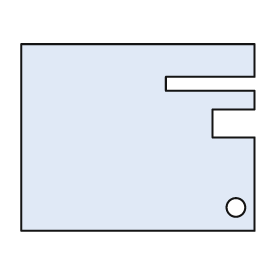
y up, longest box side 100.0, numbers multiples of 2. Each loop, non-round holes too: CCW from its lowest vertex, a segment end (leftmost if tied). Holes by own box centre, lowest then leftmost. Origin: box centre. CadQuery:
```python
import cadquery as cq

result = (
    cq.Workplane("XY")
    .moveTo(-50.0, -40.0)
    .lineTo(50.0, -40.0)
    .lineTo(50.0, 0.0)
    .lineTo(32.0, 0.0)
    .lineTo(32.0, 12.0)
    .lineTo(50.0, 12.0)
    .lineTo(50.0, 20.0)
    .lineTo(12.0, 20.0)
    .lineTo(12.0, 26.0)
    .lineTo(50.0, 26.0)
    .lineTo(50.0, 40.0)
    .lineTo(-50.0, 40.0)
    .close()
    .moveTo(42.0, -30.0)
    .circle(4.0)
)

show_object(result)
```